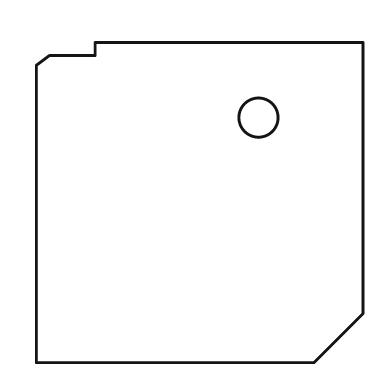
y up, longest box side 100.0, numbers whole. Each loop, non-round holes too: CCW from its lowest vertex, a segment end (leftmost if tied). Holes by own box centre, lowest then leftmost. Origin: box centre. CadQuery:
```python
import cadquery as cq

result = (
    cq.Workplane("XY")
    .moveTo(-50.0, -49.0)
    .lineTo(35.0, -49.0)
    .lineTo(50.0, -34.0)
    .lineTo(50.0, 49.0)
    .lineTo(-32.0, 49.0)
    .lineTo(-32.0, 45.0)
    .lineTo(-46.0, 45.0)
    .lineTo(-50.0, 42.0)
    .close()
    .moveTo(18.0, 26.0)
    .circle(6.0)
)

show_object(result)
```